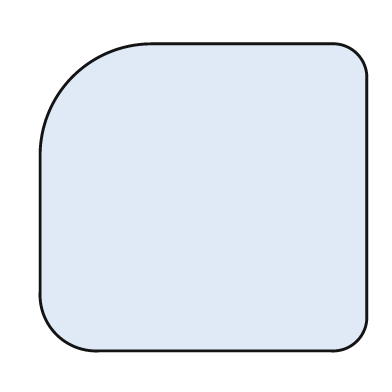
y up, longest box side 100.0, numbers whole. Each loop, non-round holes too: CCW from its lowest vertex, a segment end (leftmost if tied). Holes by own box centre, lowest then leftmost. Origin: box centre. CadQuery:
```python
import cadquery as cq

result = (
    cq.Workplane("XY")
    .moveTo(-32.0, -47.0)
    .lineTo(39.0, -47.0)
    .threePointArc((47.0, -44.0), (50.0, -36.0))
    .lineTo(50.0, 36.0)
    .threePointArc((47.0, 44.0), (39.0, 47.0))
    .lineTo(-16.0, 47.0)
    .threePointArc((-40.0, 37.0), (-50.0, 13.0))
    .lineTo(-50.0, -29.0)
    .threePointArc((-45.0, -42.0), (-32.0, -47.0))
    .close()
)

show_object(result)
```